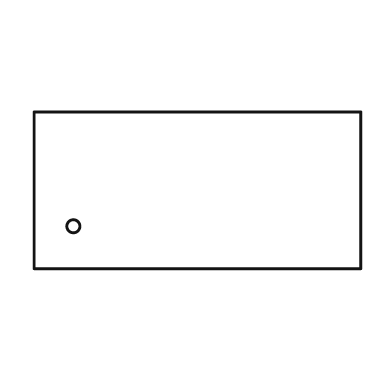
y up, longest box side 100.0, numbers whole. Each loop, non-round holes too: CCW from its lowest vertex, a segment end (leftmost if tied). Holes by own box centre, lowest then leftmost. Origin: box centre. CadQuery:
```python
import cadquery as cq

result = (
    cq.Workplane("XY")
    .moveTo(-50.0, -24.0)
    .lineTo(50.0, -24.0)
    .lineTo(50.0, 24.0)
    .lineTo(-50.0, 24.0)
    .close()
    .moveTo(-38.0, -11.0)
    .circle(2.0)
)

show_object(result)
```